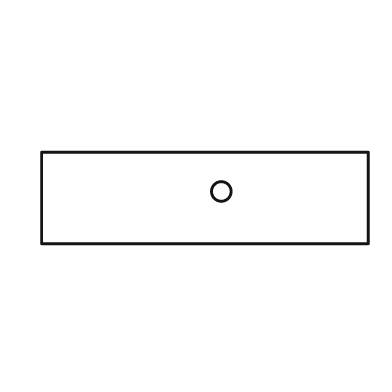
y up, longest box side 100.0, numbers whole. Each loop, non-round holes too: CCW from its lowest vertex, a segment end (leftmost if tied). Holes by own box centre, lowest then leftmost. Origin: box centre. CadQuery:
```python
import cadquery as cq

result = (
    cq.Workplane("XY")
    .moveTo(-50.0, -14.0)
    .lineTo(50.0, -14.0)
    .lineTo(50.0, 14.0)
    .lineTo(-50.0, 14.0)
    .close()
    .moveTo(5.0, 2.0)
    .circle(3.0)
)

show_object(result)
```